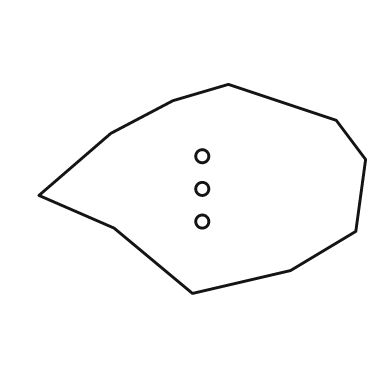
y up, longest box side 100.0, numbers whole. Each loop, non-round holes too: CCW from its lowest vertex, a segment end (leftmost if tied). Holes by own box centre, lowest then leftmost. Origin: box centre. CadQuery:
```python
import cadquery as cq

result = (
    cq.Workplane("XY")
    .moveTo(-3.0, -32.0)
    .lineTo(27.0, -25.0)
    .lineTo(47.0, -13.0)
    .lineTo(50.0, 9.0)
    .lineTo(41.0, 21.0)
    .lineTo(8.0, 32.0)
    .lineTo(-9.0, 27.0)
    .lineTo(-28.0, 17.0)
    .lineTo(-50.0, -2.0)
    .lineTo(-27.0, -12.0)
    .close()
    .moveTo(0.0, -10.0)
    .circle(2.0)
    .moveTo(0.0, 0.0)
    .circle(2.0)
    .moveTo(0.0, 10.0)
    .circle(2.0)
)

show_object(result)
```